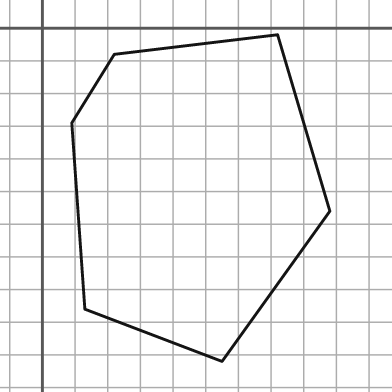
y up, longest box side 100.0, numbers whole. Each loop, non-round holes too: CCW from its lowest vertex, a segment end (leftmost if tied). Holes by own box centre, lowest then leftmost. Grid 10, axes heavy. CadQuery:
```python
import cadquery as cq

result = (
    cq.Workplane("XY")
    .moveTo(55.0, -102.0)
    .lineTo(88.0, -56.0)
    .lineTo(72.0, -2.0)
    .lineTo(22.0, -8.0)
    .lineTo(9.0, -29.0)
    .lineTo(13.0, -86.0)
    .close()
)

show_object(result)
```